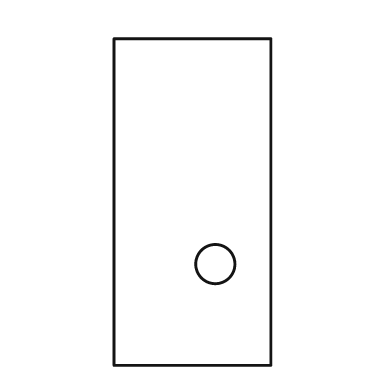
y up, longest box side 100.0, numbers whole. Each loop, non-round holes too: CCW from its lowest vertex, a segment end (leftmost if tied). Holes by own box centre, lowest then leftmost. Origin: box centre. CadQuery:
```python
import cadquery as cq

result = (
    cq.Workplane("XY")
    .moveTo(-24.0, -50.0)
    .lineTo(24.0, -50.0)
    .lineTo(24.0, 50.0)
    .lineTo(-24.0, 50.0)
    .close()
    .moveTo(7.0, -19.0)
    .circle(6.0)
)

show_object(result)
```